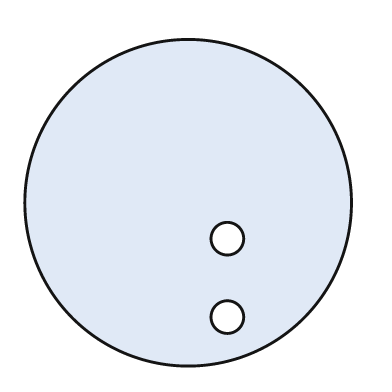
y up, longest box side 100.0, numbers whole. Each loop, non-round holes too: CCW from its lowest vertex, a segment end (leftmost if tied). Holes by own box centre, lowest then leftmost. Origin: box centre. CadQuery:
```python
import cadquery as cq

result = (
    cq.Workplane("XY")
    .moveTo(0.0, 0.0)
    .circle(50.0)
    .moveTo(12.0, -35.0)
    .circle(5.0)
    .moveTo(12.0, -11.0)
    .circle(5.0)
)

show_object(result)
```